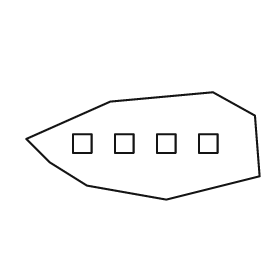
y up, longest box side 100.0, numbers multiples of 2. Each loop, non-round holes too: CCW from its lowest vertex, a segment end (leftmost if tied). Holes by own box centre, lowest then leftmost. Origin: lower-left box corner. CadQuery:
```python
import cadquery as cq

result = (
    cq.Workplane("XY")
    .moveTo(60.0, 0.0)
    .lineTo(100.0, 10.0)
    .lineTo(98.0, 36.0)
    .lineTo(80.0, 46.0)
    .lineTo(36.0, 42.0)
    .lineTo(0.0, 26.0)
    .lineTo(10.0, 16.0)
    .lineTo(26.0, 6.0)
    .close()
    .moveTo(20.0, 20.0)
    .lineTo(28.0, 20.0)
    .lineTo(28.0, 28.0)
    .lineTo(20.0, 28.0)
    .close()
    .moveTo(38.0, 20.0)
    .lineTo(46.0, 20.0)
    .lineTo(46.0, 28.0)
    .lineTo(38.0, 28.0)
    .close()
    .moveTo(56.0, 20.0)
    .lineTo(64.0, 20.0)
    .lineTo(64.0, 28.0)
    .lineTo(56.0, 28.0)
    .close()
    .moveTo(74.0, 20.0)
    .lineTo(82.0, 20.0)
    .lineTo(82.0, 28.0)
    .lineTo(74.0, 28.0)
    .close()
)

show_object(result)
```